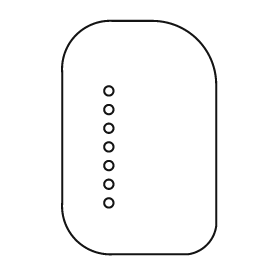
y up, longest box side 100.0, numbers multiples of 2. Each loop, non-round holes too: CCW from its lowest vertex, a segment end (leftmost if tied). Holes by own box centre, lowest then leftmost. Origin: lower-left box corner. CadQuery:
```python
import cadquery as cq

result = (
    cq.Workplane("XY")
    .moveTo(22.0, 0.0)
    .lineTo(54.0, 0.0)
    .threePointArc((62.0, 4.0), (66.0, 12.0))
    .lineTo(66.0, 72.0)
    .threePointArc((58.0, 92.0), (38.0, 100.0))
    .lineTo(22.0, 100.0)
    .threePointArc((6.0, 94.0), (0.0, 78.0))
    .lineTo(0.0, 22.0)
    .threePointArc((6.0, 6.0), (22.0, 0.0))
    .close()
    .moveTo(20.0, 22.0)
    .circle(2.0)
    .moveTo(20.0, 30.0)
    .circle(2.0)
    .moveTo(20.0, 38.0)
    .circle(2.0)
    .moveTo(20.0, 46.0)
    .circle(2.0)
    .moveTo(20.0, 54.0)
    .circle(2.0)
    .moveTo(20.0, 62.0)
    .circle(2.0)
    .moveTo(20.0, 70.0)
    .circle(2.0)
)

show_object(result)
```